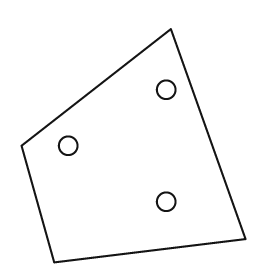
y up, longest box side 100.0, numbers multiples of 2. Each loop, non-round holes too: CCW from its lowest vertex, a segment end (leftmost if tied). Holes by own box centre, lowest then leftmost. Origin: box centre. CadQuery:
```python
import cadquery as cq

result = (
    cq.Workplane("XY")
    .moveTo(-34.0, -50.0)
    .lineTo(48.0, -40.0)
    .lineTo(16.0, 50.0)
    .lineTo(-48.0, 0.0)
    .close()
    .moveTo(14.0, -24.0)
    .circle(4.0)
    .moveTo(-28.0, 0.0)
    .circle(4.0)
    .moveTo(14.0, 24.0)
    .circle(4.0)
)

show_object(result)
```